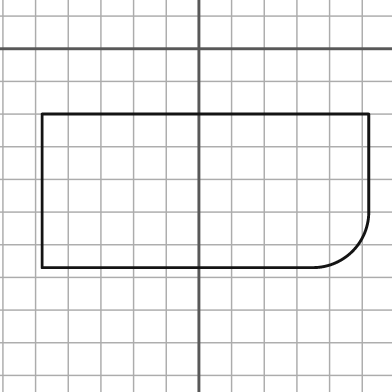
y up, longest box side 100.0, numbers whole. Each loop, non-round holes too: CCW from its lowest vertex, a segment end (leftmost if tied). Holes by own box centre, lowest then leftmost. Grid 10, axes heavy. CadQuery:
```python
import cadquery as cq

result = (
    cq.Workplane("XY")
    .moveTo(-48.0, -67.0)
    .lineTo(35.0, -67.0)
    .threePointArc((47.0, -62.0), (52.0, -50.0))
    .lineTo(52.0, -20.0)
    .lineTo(-48.0, -20.0)
    .close()
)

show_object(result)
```